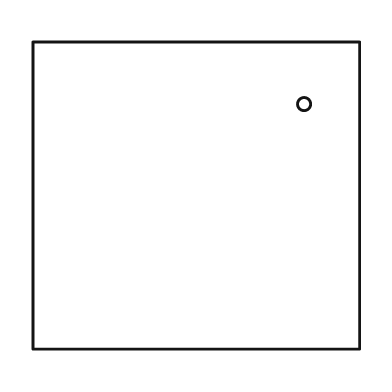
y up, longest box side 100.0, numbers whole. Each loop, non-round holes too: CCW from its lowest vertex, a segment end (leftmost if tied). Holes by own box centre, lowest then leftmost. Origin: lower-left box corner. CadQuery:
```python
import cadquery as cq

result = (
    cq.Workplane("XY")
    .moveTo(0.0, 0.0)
    .lineTo(100.0, 0.0)
    .lineTo(100.0, 94.0)
    .lineTo(0.0, 94.0)
    .close()
    .moveTo(83.0, 75.0)
    .circle(2.0)
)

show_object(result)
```